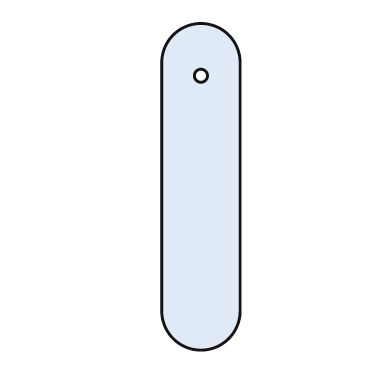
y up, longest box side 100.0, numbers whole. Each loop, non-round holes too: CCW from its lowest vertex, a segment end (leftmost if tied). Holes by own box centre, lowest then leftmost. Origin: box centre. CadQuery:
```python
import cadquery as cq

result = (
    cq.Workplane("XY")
    .moveTo(-12.0, -38.0)
    .threePointArc((0.0, -50.0), (12.0, -38.0))
    .lineTo(12.0, 38.0)
    .threePointArc((0.0, 50.0), (-12.0, 38.0))
    .close()
    .moveTo(0.0, 34.0)
    .circle(2.0)
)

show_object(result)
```